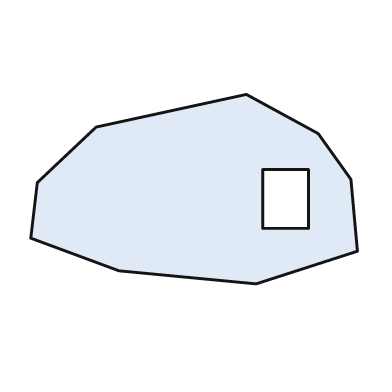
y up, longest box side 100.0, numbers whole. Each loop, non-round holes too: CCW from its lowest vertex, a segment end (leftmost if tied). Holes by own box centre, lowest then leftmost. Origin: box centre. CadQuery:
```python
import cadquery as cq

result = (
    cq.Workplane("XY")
    .moveTo(19.0, -29.0)
    .lineTo(50.0, -19.0)
    .lineTo(48.0, 3.0)
    .lineTo(38.0, 17.0)
    .lineTo(16.0, 29.0)
    .lineTo(-30.0, 19.0)
    .lineTo(-48.0, 2.0)
    .lineTo(-50.0, -15.0)
    .lineTo(-23.0, -25.0)
    .close()
    .moveTo(21.0, -12.0)
    .lineTo(35.0, -12.0)
    .lineTo(35.0, 6.0)
    .lineTo(21.0, 6.0)
    .close()
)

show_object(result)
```